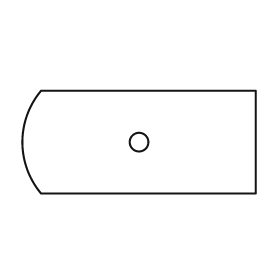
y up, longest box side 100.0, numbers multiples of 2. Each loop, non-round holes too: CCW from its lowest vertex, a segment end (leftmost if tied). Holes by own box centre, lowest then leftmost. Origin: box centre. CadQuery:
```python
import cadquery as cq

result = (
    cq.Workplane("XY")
    .moveTo(-42.0, -22.0)
    .lineTo(50.0, -22.0)
    .lineTo(50.0, 22.0)
    .lineTo(-42.0, 22.0)
    .threePointArc((-50.0, 0.0), (-42.0, -22.0))
    .close()
    .moveTo(0.0, 0.0)
    .circle(4.0)
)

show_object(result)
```